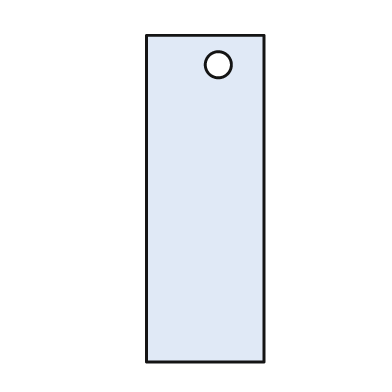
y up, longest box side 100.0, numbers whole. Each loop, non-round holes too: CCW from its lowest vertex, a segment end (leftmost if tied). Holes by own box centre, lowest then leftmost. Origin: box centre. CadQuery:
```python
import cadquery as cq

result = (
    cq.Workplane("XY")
    .moveTo(-18.0, -50.0)
    .lineTo(18.0, -50.0)
    .lineTo(18.0, 50.0)
    .lineTo(-18.0, 50.0)
    .close()
    .moveTo(4.0, 41.0)
    .circle(4.0)
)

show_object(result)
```